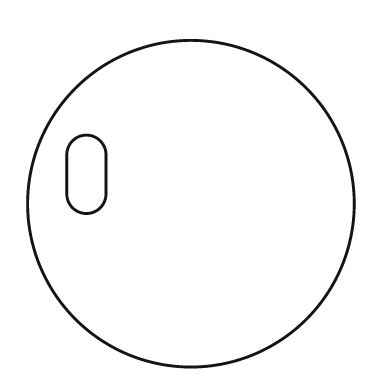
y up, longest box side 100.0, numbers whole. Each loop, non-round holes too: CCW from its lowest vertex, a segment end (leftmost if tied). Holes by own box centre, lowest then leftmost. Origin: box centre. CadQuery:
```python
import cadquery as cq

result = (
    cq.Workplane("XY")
    .moveTo(0.0, 0.0)
    .circle(50.0)
    .moveTo(-38.0, 3.0)
    .threePointArc((-32.0, -3.0), (-26.0, 3.0))
    .lineTo(-26.0, 15.0)
    .threePointArc((-32.0, 21.0), (-38.0, 15.0))
    .close()
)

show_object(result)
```